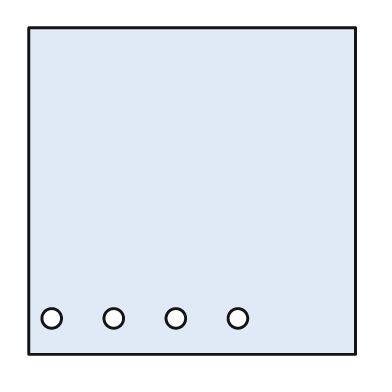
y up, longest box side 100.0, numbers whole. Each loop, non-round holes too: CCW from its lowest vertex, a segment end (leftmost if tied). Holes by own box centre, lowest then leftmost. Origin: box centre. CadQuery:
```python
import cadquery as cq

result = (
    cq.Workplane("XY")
    .moveTo(-50.0, -50.0)
    .lineTo(50.0, -50.0)
    .lineTo(50.0, 50.0)
    .lineTo(-50.0, 50.0)
    .close()
    .moveTo(-43.0, -39.0)
    .circle(3.0)
    .moveTo(-24.0, -39.0)
    .circle(3.0)
    .moveTo(-5.0, -39.0)
    .circle(3.0)
    .moveTo(14.0, -39.0)
    .circle(3.0)
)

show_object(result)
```